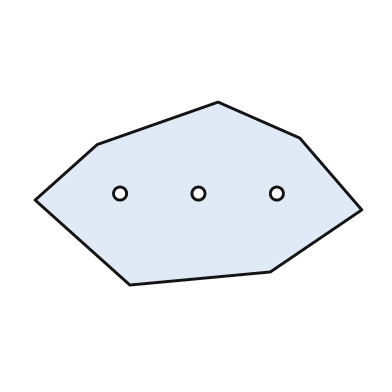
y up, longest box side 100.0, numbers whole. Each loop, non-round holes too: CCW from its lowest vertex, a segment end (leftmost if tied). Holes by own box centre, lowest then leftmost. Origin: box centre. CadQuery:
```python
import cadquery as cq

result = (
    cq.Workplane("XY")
    .moveTo(-21.0, -28.0)
    .lineTo(22.0, -24.0)
    .lineTo(50.0, -5.0)
    .lineTo(31.0, 17.0)
    .lineTo(6.0, 28.0)
    .lineTo(-31.0, 15.0)
    .lineTo(-50.0, -2.0)
    .close()
    .moveTo(-24.0, 0.0)
    .circle(2.0)
    .moveTo(0.0, 0.0)
    .circle(2.0)
    .moveTo(24.0, 0.0)
    .circle(2.0)
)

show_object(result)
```